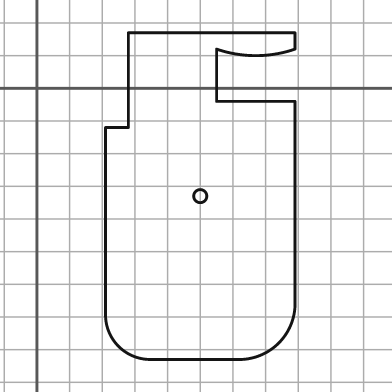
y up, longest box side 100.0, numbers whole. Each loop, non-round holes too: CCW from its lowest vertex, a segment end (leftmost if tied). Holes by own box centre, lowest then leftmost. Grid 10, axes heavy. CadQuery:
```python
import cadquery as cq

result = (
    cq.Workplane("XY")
    .moveTo(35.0, -83.0)
    .lineTo(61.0, -83.0)
    .threePointArc((74.0, -78.0), (79.0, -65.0))
    .lineTo(79.0, -4.0)
    .lineTo(55.0, -4.0)
    .lineTo(55.0, 12.0)
    .threePointArc((67.0, 10.0), (79.0, 12.0))
    .lineTo(79.0, 17.0)
    .lineTo(28.0, 17.0)
    .lineTo(28.0, -12.0)
    .lineTo(21.0, -12.0)
    .lineTo(21.0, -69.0)
    .threePointArc((25.0, -79.0), (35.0, -83.0))
    .close()
    .moveTo(50.0, -33.0)
    .circle(2.0)
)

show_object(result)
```